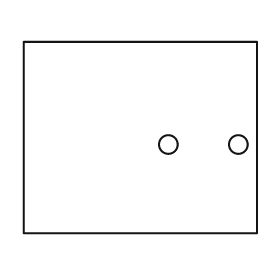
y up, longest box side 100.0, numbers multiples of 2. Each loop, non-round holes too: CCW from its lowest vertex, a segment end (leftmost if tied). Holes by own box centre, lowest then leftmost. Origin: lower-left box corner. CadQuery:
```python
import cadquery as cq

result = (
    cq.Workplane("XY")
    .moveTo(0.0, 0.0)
    .lineTo(100.0, 0.0)
    .lineTo(100.0, 82.0)
    .lineTo(0.0, 82.0)
    .close()
    .moveTo(62.0, 38.0)
    .circle(4.0)
    .moveTo(92.0, 38.0)
    .circle(4.0)
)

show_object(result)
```